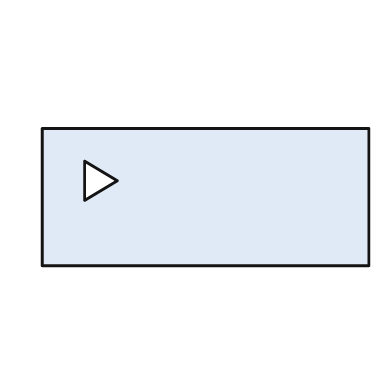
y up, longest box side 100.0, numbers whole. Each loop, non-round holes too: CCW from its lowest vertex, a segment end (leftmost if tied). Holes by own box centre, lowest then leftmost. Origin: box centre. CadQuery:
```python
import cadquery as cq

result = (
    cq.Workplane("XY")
    .moveTo(-50.0, -21.0)
    .lineTo(50.0, -21.0)
    .lineTo(50.0, 21.0)
    .lineTo(-50.0, 21.0)
    .close()
    .moveTo(-37.0, -1.0)
    .lineTo(-27.0, 5.0)
    .lineTo(-37.0, 11.0)
    .close()
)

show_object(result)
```